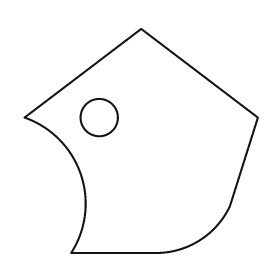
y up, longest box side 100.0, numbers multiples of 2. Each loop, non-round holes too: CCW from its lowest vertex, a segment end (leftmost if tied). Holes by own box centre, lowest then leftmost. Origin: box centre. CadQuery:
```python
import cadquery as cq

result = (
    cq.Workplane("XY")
    .moveTo(-30.0, -48.0)
    .lineTo(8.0, -48.0)
    .threePointArc((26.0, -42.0), (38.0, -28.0))
    .lineTo(50.0, 10.0)
    .lineTo(0.0, 48.0)
    .lineTo(-50.0, 10.0)
    .threePointArc((-26.0, -14.0), (-30.0, -48.0))
    .close()
    .moveTo(-18.0, 10.0)
    .circle(8.0)
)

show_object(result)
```